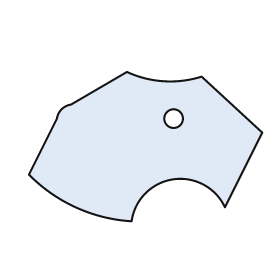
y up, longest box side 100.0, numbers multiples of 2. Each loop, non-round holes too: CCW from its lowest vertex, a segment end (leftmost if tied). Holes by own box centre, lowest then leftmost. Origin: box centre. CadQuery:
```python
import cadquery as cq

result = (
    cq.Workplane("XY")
    .moveTo(-6.0, -32.0)
    .threePointArc((12.0, -14.0), (34.0, -26.0))
    .lineTo(50.0, 6.0)
    .lineTo(24.0, 30.0)
    .threePointArc((8.0, 28.0), (-8.0, 32.0))
    .lineTo(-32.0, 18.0)
    .threePointArc((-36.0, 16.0), (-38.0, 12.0))
    .lineTo(-50.0, -12.0)
    .threePointArc((-30.0, -26.0), (-6.0, -32.0))
    .close()
    .moveTo(12.0, 12.0)
    .circle(4.0)
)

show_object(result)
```